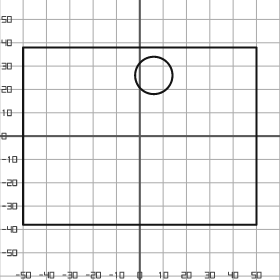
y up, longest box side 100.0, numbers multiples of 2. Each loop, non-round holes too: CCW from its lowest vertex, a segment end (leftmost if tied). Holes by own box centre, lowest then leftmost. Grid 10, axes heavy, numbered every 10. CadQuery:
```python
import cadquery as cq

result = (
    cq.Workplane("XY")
    .moveTo(-50.0, -38.0)
    .lineTo(50.0, -38.0)
    .lineTo(50.0, 38.0)
    .lineTo(-50.0, 38.0)
    .close()
    .moveTo(6.0, 26.0)
    .circle(8.0)
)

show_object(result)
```